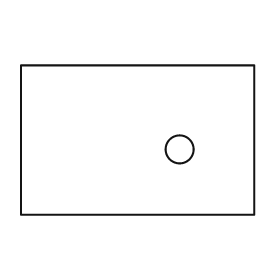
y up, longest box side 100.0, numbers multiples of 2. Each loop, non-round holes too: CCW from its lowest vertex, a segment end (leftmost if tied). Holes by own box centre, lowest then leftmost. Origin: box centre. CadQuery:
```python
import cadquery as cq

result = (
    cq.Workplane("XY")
    .moveTo(-50.0, -32.0)
    .lineTo(50.0, -32.0)
    .lineTo(50.0, 32.0)
    .lineTo(-50.0, 32.0)
    .close()
    .moveTo(18.0, -4.0)
    .circle(6.0)
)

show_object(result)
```